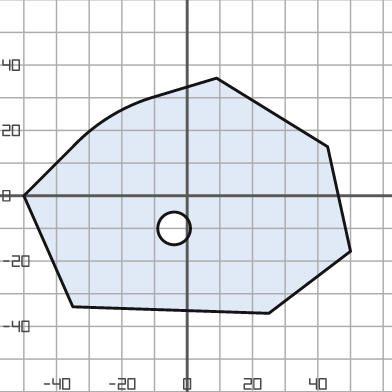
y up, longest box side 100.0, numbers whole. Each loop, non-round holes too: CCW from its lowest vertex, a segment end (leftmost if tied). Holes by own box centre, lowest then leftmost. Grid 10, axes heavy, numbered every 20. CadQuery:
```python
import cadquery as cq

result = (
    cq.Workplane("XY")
    .moveTo(25.0, -36.0)
    .lineTo(50.0, -17.0)
    .lineTo(43.0, 15.0)
    .lineTo(9.0, 36.0)
    .lineTo(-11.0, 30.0)
    .threePointArc((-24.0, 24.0), (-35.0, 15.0))
    .lineTo(-50.0, 0.0)
    .lineTo(-35.0, -34.0)
    .close()
    .moveTo(-4.0, -10.0)
    .circle(5.0)
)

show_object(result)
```